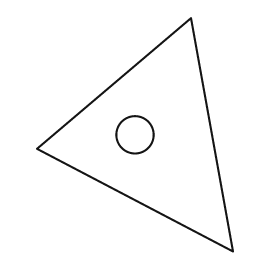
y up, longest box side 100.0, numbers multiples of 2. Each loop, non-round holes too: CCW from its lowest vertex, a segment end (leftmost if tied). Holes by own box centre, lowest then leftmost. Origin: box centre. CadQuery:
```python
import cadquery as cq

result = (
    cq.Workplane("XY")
    .moveTo(42.0, -50.0)
    .lineTo(24.0, 50.0)
    .lineTo(-42.0, -6.0)
    .close()
    .moveTo(0.0, 0.0)
    .circle(8.0)
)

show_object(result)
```